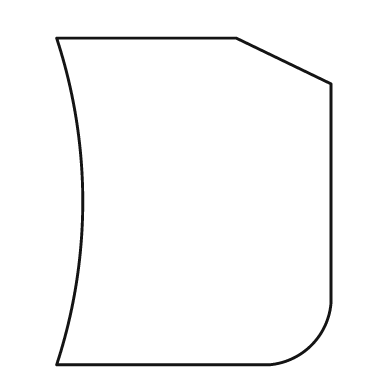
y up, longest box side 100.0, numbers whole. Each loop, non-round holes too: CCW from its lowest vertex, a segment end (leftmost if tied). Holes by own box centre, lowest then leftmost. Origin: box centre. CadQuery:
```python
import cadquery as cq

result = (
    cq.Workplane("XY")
    .moveTo(-42.0, -50.0)
    .lineTo(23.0, -50.0)
    .threePointArc((36.0, -44.0), (42.0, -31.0))
    .lineTo(42.0, 36.0)
    .lineTo(13.0, 50.0)
    .lineTo(-42.0, 50.0)
    .threePointArc((-34.0, 0.0), (-42.0, -50.0))
    .close()
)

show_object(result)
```